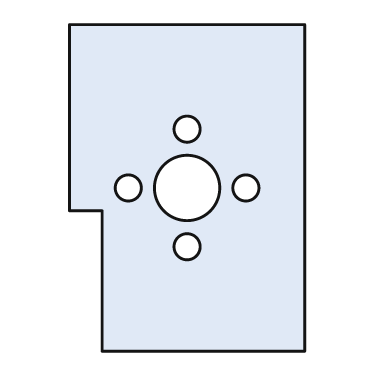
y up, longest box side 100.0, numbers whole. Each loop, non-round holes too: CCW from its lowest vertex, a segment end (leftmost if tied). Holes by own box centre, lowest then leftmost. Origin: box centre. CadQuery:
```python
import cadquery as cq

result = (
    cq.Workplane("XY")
    .moveTo(-26.0, -50.0)
    .lineTo(36.0, -50.0)
    .lineTo(36.0, 50.0)
    .lineTo(-36.0, 50.0)
    .lineTo(-36.0, -7.0)
    .lineTo(-26.0, -7.0)
    .close()
    .moveTo(0.0, -18.0)
    .circle(4.0)
    .moveTo(-18.0, 0.0)
    .circle(4.0)
    .moveTo(0.0, 0.0)
    .circle(10.0)
    .moveTo(18.0, 0.0)
    .circle(4.0)
    .moveTo(0.0, 18.0)
    .circle(4.0)
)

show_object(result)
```